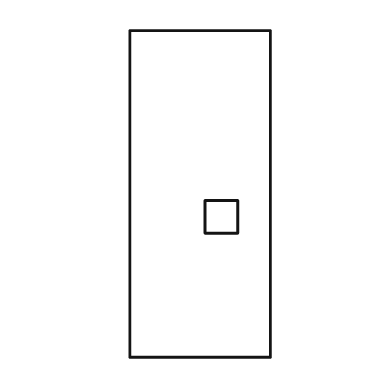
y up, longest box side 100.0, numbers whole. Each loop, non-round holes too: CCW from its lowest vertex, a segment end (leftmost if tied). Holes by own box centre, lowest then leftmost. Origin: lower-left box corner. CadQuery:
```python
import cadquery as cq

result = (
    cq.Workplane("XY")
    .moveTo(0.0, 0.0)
    .lineTo(43.0, 0.0)
    .lineTo(43.0, 100.0)
    .lineTo(0.0, 100.0)
    .close()
    .moveTo(23.0, 38.0)
    .lineTo(33.0, 38.0)
    .lineTo(33.0, 48.0)
    .lineTo(23.0, 48.0)
    .close()
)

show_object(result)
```